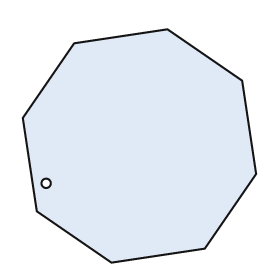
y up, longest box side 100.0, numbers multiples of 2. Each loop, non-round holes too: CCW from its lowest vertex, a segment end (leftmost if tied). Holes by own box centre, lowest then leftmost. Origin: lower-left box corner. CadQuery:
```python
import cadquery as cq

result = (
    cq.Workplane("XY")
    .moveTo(38.0, 0.0)
    .lineTo(78.0, 6.0)
    .lineTo(100.0, 38.0)
    .lineTo(94.0, 78.0)
    .lineTo(62.0, 100.0)
    .lineTo(22.0, 94.0)
    .lineTo(0.0, 62.0)
    .lineTo(6.0, 22.0)
    .close()
    .moveTo(10.0, 34.0)
    .circle(2.0)
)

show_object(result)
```